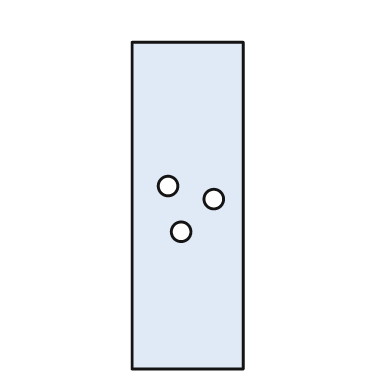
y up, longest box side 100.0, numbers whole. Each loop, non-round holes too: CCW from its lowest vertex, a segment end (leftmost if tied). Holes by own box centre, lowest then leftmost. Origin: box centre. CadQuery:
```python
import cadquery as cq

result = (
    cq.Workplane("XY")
    .moveTo(-17.0, -50.0)
    .lineTo(17.0, -50.0)
    .lineTo(17.0, 50.0)
    .lineTo(-17.0, 50.0)
    .close()
    .moveTo(-2.0, -8.0)
    .circle(3.0)
    .moveTo(8.0, 2.0)
    .circle(3.0)
    .moveTo(-6.0, 6.0)
    .circle(3.0)
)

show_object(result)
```